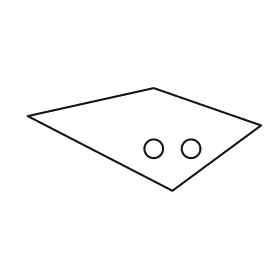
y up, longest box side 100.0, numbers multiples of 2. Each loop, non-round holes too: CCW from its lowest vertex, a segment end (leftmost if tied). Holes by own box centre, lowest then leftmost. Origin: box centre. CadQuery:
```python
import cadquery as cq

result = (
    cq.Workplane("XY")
    .moveTo(12.0, -22.0)
    .lineTo(50.0, 6.0)
    .lineTo(4.0, 22.0)
    .lineTo(-50.0, 10.0)
    .close()
    .moveTo(4.0, -4.0)
    .circle(4.0)
    .moveTo(20.0, -4.0)
    .circle(4.0)
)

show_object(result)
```